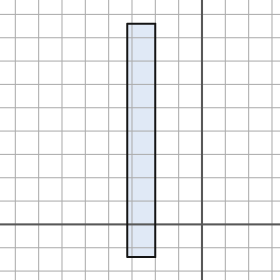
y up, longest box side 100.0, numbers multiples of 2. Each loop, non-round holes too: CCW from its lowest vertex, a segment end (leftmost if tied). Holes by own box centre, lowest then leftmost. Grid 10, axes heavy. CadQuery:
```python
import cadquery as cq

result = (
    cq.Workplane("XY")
    .moveTo(-32.0, -14.0)
    .lineTo(-20.0, -14.0)
    .lineTo(-20.0, 86.0)
    .lineTo(-32.0, 86.0)
    .close()
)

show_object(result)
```